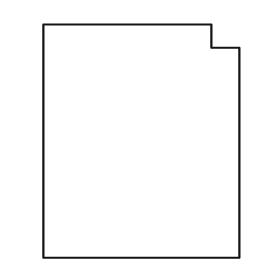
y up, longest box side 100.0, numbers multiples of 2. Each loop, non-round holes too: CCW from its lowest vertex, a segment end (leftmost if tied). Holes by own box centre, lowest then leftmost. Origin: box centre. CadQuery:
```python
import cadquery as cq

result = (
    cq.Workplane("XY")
    .moveTo(-42.0, -50.0)
    .lineTo(42.0, -50.0)
    .lineTo(42.0, 40.0)
    .lineTo(30.0, 40.0)
    .lineTo(30.0, 50.0)
    .lineTo(-42.0, 50.0)
    .close()
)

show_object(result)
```